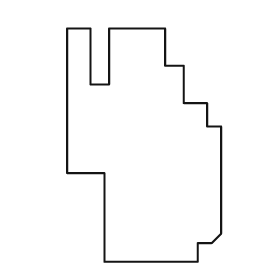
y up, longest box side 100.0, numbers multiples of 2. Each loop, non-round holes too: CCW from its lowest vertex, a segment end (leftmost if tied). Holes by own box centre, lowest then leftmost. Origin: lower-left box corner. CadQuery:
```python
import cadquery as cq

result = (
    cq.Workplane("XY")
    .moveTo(16.0, 0.0)
    .lineTo(56.0, 0.0)
    .lineTo(56.0, 8.0)
    .lineTo(62.0, 8.0)
    .lineTo(66.0, 12.0)
    .lineTo(66.0, 58.0)
    .lineTo(60.0, 58.0)
    .lineTo(60.0, 68.0)
    .lineTo(50.0, 68.0)
    .lineTo(50.0, 84.0)
    .lineTo(42.0, 84.0)
    .lineTo(42.0, 100.0)
    .lineTo(18.0, 100.0)
    .lineTo(18.0, 76.0)
    .lineTo(10.0, 76.0)
    .lineTo(10.0, 100.0)
    .lineTo(0.0, 100.0)
    .lineTo(0.0, 38.0)
    .lineTo(16.0, 38.0)
    .close()
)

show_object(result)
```